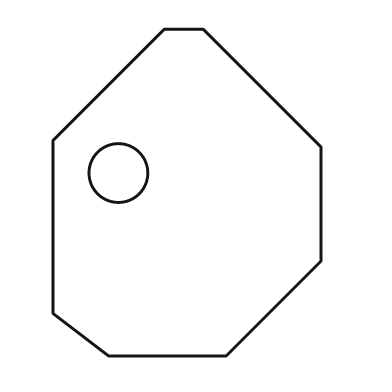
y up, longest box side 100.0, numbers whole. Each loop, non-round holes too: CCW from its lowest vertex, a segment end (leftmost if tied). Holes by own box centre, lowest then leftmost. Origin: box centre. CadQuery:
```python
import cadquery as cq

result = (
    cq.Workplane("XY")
    .moveTo(-24.0, -50.0)
    .lineTo(12.0, -50.0)
    .lineTo(41.0, -21.0)
    .lineTo(41.0, 14.0)
    .lineTo(5.0, 50.0)
    .lineTo(-7.0, 50.0)
    .lineTo(-41.0, 16.0)
    .lineTo(-41.0, -37.0)
    .close()
    .moveTo(-21.0, 6.0)
    .circle(9.0)
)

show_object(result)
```